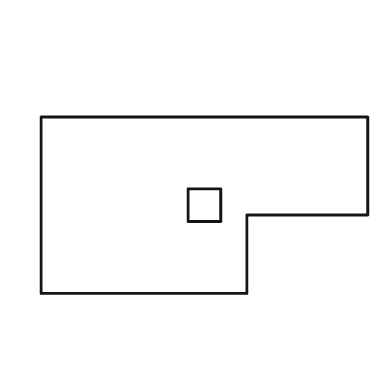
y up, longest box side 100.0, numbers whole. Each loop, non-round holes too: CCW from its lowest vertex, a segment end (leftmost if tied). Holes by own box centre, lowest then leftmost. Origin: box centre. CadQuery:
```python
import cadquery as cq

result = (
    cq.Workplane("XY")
    .moveTo(-50.0, -27.0)
    .lineTo(13.0, -27.0)
    .lineTo(13.0, -3.0)
    .lineTo(50.0, -3.0)
    .lineTo(50.0, 27.0)
    .lineTo(-50.0, 27.0)
    .close()
    .moveTo(-5.0, -5.0)
    .lineTo(5.0, -5.0)
    .lineTo(5.0, 5.0)
    .lineTo(-5.0, 5.0)
    .close()
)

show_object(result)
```